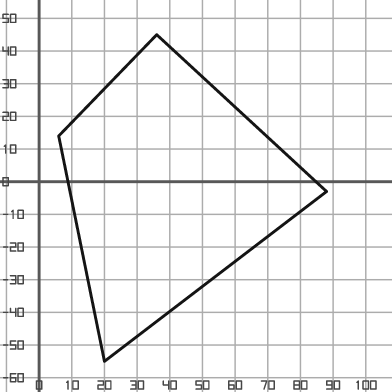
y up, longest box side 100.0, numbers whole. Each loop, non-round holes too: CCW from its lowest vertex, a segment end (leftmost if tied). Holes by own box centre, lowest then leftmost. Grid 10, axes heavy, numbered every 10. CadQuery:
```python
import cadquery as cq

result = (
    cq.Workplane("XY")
    .moveTo(20.0, -55.0)
    .lineTo(88.0, -3.0)
    .lineTo(36.0, 45.0)
    .lineTo(6.0, 14.0)
    .close()
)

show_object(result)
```